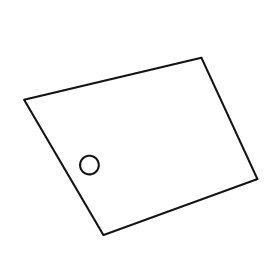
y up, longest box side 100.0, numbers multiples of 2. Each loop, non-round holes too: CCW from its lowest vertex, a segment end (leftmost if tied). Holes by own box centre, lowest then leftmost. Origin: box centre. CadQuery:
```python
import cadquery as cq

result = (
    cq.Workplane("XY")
    .moveTo(-16.0, -38.0)
    .lineTo(50.0, -14.0)
    .lineTo(26.0, 38.0)
    .lineTo(-50.0, 20.0)
    .close()
    .moveTo(-22.0, -8.0)
    .circle(4.0)
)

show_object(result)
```